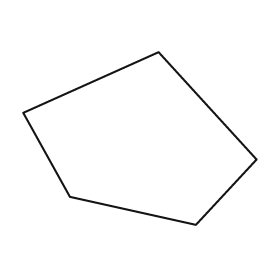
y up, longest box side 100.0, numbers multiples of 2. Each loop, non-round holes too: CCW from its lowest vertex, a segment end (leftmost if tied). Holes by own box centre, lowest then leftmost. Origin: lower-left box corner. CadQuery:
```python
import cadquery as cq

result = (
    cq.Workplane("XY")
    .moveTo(74.0, 0.0)
    .lineTo(100.0, 28.0)
    .lineTo(58.0, 74.0)
    .lineTo(0.0, 48.0)
    .lineTo(20.0, 12.0)
    .close()
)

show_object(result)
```